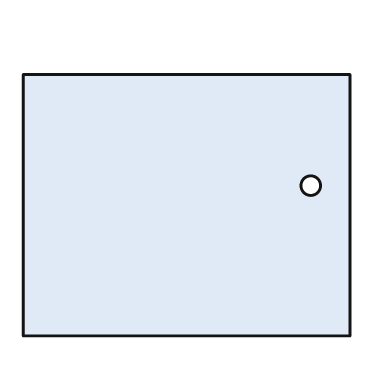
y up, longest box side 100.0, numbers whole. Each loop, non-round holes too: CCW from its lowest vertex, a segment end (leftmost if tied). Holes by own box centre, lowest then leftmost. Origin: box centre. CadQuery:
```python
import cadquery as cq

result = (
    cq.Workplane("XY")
    .moveTo(-50.0, -40.0)
    .lineTo(50.0, -40.0)
    .lineTo(50.0, 40.0)
    .lineTo(-50.0, 40.0)
    .close()
    .moveTo(38.0, 6.0)
    .circle(3.0)
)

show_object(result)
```